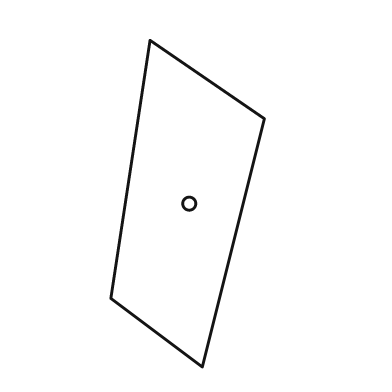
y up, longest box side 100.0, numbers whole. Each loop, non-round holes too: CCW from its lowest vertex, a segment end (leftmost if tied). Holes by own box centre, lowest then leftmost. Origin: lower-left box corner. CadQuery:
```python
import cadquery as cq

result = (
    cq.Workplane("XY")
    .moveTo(28.0, 0.0)
    .lineTo(47.0, 76.0)
    .lineTo(12.0, 100.0)
    .lineTo(0.0, 21.0)
    .close()
    .moveTo(24.0, 50.0)
    .circle(2.0)
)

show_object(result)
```